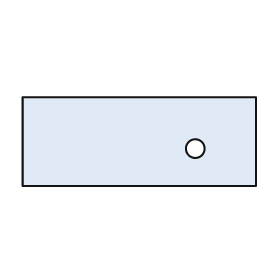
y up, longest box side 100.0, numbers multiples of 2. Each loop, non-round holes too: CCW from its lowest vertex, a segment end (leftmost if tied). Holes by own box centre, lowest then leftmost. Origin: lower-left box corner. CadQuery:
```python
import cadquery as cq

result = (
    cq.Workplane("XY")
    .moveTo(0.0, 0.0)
    .lineTo(100.0, 0.0)
    .lineTo(100.0, 38.0)
    .lineTo(0.0, 38.0)
    .close()
    .moveTo(74.0, 16.0)
    .circle(4.0)
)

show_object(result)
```